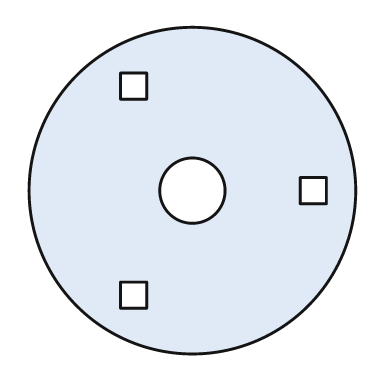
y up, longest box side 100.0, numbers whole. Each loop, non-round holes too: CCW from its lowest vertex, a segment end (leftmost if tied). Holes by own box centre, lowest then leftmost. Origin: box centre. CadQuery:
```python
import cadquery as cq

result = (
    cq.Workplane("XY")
    .moveTo(0.0, 0.0)
    .circle(50.0)
    .moveTo(-22.0, -36.0)
    .lineTo(-14.0, -36.0)
    .lineTo(-14.0, -28.0)
    .lineTo(-22.0, -28.0)
    .close()
    .moveTo(0.0, 0.0)
    .circle(10.0)
    .moveTo(33.0, -4.0)
    .lineTo(41.0, -4.0)
    .lineTo(41.0, 4.0)
    .lineTo(33.0, 4.0)
    .close()
    .moveTo(-22.0, 28.0)
    .lineTo(-14.0, 28.0)
    .lineTo(-14.0, 36.0)
    .lineTo(-22.0, 36.0)
    .close()
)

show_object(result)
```